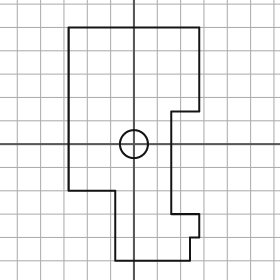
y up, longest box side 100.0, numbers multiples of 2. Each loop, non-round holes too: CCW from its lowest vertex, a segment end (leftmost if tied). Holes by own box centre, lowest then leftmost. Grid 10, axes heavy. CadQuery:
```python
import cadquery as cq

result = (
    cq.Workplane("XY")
    .moveTo(-8.0, -50.0)
    .lineTo(24.0, -50.0)
    .lineTo(24.0, -40.0)
    .lineTo(28.0, -40.0)
    .lineTo(28.0, -30.0)
    .lineTo(16.0, -30.0)
    .lineTo(16.0, 14.0)
    .lineTo(28.0, 14.0)
    .lineTo(28.0, 50.0)
    .lineTo(-28.0, 50.0)
    .lineTo(-28.0, -20.0)
    .lineTo(-8.0, -20.0)
    .close()
    .moveTo(0.0, 0.0)
    .circle(6.0)
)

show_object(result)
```